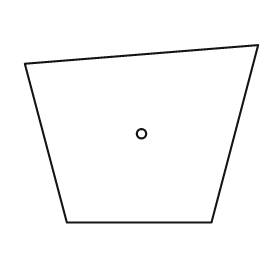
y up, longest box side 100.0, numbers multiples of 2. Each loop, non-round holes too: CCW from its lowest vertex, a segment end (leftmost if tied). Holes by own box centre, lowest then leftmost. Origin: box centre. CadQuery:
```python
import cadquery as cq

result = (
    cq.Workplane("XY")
    .moveTo(-32.0, -38.0)
    .lineTo(30.0, -38.0)
    .lineTo(50.0, 38.0)
    .lineTo(-50.0, 30.0)
    .close()
    .moveTo(0.0, 0.0)
    .circle(2.0)
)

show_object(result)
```